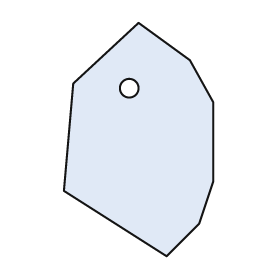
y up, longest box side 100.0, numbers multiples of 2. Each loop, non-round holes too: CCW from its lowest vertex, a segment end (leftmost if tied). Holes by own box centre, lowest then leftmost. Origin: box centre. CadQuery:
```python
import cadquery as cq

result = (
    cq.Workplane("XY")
    .moveTo(12.0, -50.0)
    .lineTo(26.0, -36.0)
    .lineTo(32.0, -18.0)
    .lineTo(32.0, 16.0)
    .lineTo(22.0, 34.0)
    .lineTo(0.0, 50.0)
    .lineTo(-28.0, 24.0)
    .lineTo(-32.0, -22.0)
    .close()
    .moveTo(-4.0, 22.0)
    .circle(4.0)
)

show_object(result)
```